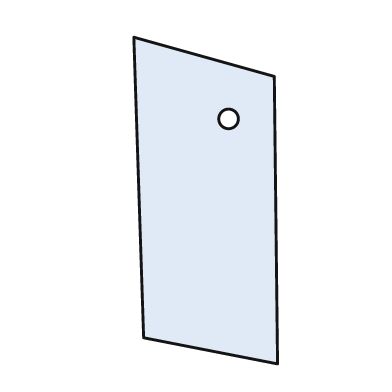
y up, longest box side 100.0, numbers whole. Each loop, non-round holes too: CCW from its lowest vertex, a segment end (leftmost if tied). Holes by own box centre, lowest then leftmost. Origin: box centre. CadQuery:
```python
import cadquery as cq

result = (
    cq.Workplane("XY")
    .moveTo(22.0, -50.0)
    .lineTo(21.0, 38.0)
    .lineTo(-22.0, 50.0)
    .lineTo(-19.0, -42.0)
    .close()
    .moveTo(7.0, 25.0)
    .circle(3.0)
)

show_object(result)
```